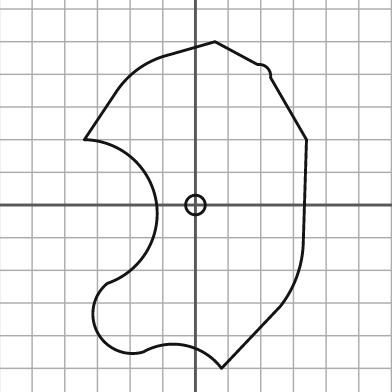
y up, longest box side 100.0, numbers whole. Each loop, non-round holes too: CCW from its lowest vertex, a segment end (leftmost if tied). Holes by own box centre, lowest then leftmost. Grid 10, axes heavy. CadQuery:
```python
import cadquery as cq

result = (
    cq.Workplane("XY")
    .moveTo(8.0, -50.0)
    .lineTo(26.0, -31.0)
    .threePointArc((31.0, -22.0), (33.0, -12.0))
    .lineTo(34.0, 20.0)
    .lineTo(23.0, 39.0)
    .threePointArc((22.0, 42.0), (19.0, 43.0))
    .lineTo(6.0, 50.0)
    .lineTo(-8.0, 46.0)
    .threePointArc((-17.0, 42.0), (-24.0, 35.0))
    .lineTo(-34.0, 20.0)
    .threePointArc((-12.0, 1.0), (-27.0, -24.0))
    .threePointArc((-30.0, -39.0), (-16.0, -45.0))
    .threePointArc((-3.0, -43.0), (8.0, -50.0))
    .close()
    .moveTo(0.0, 0.0)
    .circle(3.0)
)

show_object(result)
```